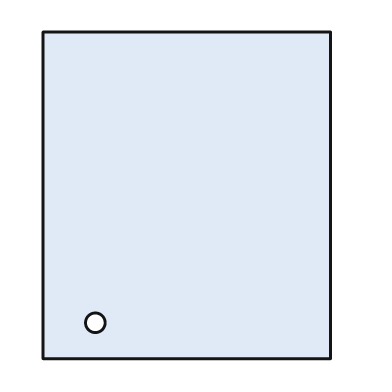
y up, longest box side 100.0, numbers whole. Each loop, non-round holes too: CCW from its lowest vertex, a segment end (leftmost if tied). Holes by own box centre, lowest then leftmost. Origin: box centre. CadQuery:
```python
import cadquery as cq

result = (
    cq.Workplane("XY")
    .moveTo(-44.0, -50.0)
    .lineTo(44.0, -50.0)
    .lineTo(44.0, 50.0)
    .lineTo(-44.0, 50.0)
    .close()
    .moveTo(-28.0, -39.0)
    .circle(3.0)
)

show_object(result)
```